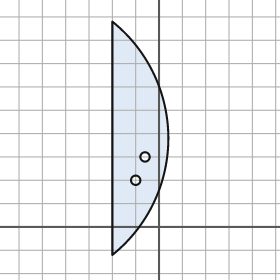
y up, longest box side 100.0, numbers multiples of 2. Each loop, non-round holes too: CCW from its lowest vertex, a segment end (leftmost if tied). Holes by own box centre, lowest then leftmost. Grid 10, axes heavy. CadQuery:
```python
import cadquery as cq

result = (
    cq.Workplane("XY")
    .moveTo(-20.0, -12.0)
    .threePointArc((4.0, 38.0), (-20.0, 88.0))
    .close()
    .moveTo(-10.0, 20.0)
    .circle(2.0)
    .moveTo(-6.0, 30.0)
    .circle(2.0)
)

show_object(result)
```